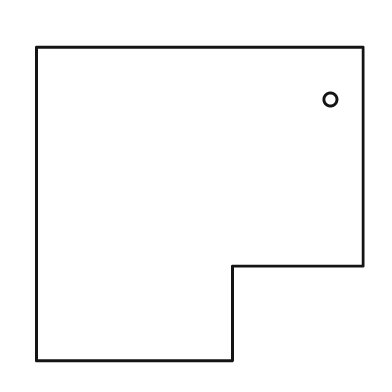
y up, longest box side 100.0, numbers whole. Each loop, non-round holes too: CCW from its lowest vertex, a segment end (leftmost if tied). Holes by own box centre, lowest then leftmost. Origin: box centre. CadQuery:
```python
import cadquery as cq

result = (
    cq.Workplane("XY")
    .moveTo(-50.0, -48.0)
    .lineTo(10.0, -48.0)
    .lineTo(10.0, -19.0)
    .lineTo(50.0, -19.0)
    .lineTo(50.0, 48.0)
    .lineTo(-50.0, 48.0)
    .close()
    .moveTo(40.0, 32.0)
    .circle(2.0)
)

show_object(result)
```